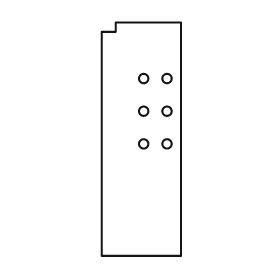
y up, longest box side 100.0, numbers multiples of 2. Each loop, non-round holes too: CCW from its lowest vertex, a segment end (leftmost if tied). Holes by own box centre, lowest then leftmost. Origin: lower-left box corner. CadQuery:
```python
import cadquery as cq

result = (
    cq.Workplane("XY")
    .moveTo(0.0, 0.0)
    .lineTo(34.0, 0.0)
    .lineTo(34.0, 100.0)
    .lineTo(6.0, 100.0)
    .lineTo(6.0, 96.0)
    .lineTo(0.0, 96.0)
    .close()
    .moveTo(18.0, 48.0)
    .circle(2.0)
    .moveTo(28.0, 48.0)
    .circle(2.0)
    .moveTo(18.0, 62.0)
    .circle(2.0)
    .moveTo(28.0, 62.0)
    .circle(2.0)
    .moveTo(18.0, 76.0)
    .circle(2.0)
    .moveTo(28.0, 76.0)
    .circle(2.0)
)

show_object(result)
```